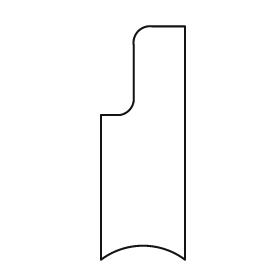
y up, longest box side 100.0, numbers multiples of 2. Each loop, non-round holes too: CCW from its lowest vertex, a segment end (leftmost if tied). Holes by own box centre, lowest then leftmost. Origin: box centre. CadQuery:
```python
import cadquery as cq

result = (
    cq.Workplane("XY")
    .moveTo(-18.0, -50.0)
    .threePointArc((0.0, -44.0), (18.0, -50.0))
    .lineTo(18.0, 50.0)
    .lineTo(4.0, 50.0)
    .threePointArc((-2.0, 48.0), (-4.0, 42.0))
    .lineTo(-4.0, 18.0)
    .threePointArc((-6.0, 14.0), (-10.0, 12.0))
    .lineTo(-18.0, 12.0)
    .close()
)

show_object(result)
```